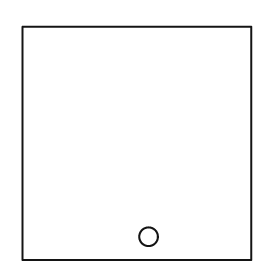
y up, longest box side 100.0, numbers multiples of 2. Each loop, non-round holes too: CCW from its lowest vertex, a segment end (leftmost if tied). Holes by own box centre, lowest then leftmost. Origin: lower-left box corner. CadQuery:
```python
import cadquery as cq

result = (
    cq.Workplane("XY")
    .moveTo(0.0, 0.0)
    .lineTo(98.0, 0.0)
    .lineTo(98.0, 100.0)
    .lineTo(0.0, 100.0)
    .close()
    .moveTo(54.0, 10.0)
    .circle(4.0)
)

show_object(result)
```